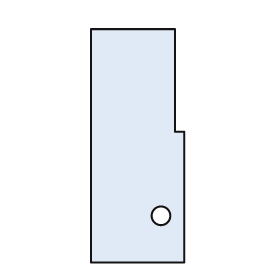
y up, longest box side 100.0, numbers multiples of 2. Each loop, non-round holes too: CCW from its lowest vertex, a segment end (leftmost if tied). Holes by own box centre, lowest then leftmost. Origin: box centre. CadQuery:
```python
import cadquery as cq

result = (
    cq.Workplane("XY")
    .moveTo(-20.0, -50.0)
    .lineTo(20.0, -50.0)
    .lineTo(20.0, 6.0)
    .lineTo(16.0, 6.0)
    .lineTo(16.0, 50.0)
    .lineTo(-20.0, 50.0)
    .close()
    .moveTo(10.0, -30.0)
    .circle(4.0)
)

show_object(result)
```